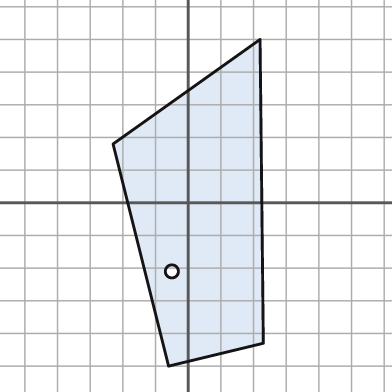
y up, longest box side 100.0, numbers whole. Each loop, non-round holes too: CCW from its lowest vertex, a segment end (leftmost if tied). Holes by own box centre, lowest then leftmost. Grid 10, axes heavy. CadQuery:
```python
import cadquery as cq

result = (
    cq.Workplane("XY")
    .moveTo(-6.0, -50.0)
    .lineTo(23.0, -43.0)
    .lineTo(22.0, 50.0)
    .lineTo(-23.0, 18.0)
    .close()
    .moveTo(-5.0, -21.0)
    .circle(2.0)
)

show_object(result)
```